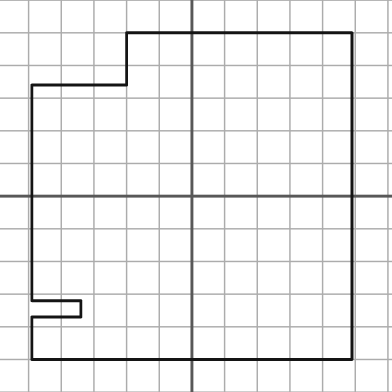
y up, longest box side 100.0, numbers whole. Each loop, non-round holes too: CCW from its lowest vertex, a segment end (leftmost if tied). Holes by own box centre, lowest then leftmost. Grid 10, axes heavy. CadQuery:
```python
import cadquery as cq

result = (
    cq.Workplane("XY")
    .moveTo(-49.0, -50.0)
    .lineTo(49.0, -50.0)
    .lineTo(49.0, 50.0)
    .lineTo(-20.0, 50.0)
    .lineTo(-20.0, 34.0)
    .lineTo(-49.0, 34.0)
    .lineTo(-49.0, -32.0)
    .lineTo(-34.0, -32.0)
    .lineTo(-34.0, -37.0)
    .lineTo(-49.0, -37.0)
    .close()
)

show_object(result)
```